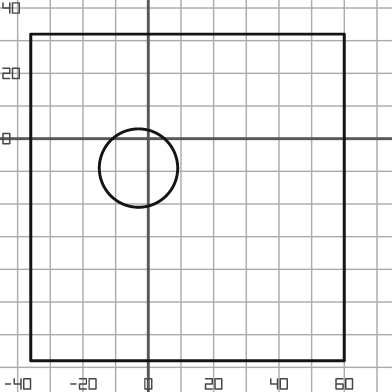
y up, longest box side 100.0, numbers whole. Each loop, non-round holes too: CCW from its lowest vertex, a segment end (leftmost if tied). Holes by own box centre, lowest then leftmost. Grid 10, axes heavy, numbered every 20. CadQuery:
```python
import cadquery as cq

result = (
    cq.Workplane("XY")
    .moveTo(-36.0, -68.0)
    .lineTo(60.0, -68.0)
    .lineTo(60.0, 32.0)
    .lineTo(-36.0, 32.0)
    .close()
    .moveTo(-3.0, -9.0)
    .circle(12.0)
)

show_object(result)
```